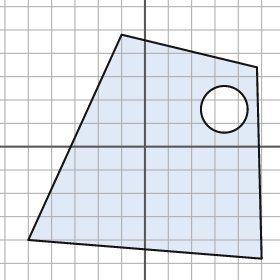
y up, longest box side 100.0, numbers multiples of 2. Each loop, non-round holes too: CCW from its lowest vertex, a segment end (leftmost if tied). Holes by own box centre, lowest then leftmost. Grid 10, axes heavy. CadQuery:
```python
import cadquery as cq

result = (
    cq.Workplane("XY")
    .moveTo(50.0, -48.0)
    .lineTo(48.0, 34.0)
    .lineTo(-10.0, 48.0)
    .lineTo(-50.0, -40.0)
    .close()
    .moveTo(34.0, 16.0)
    .circle(10.0)
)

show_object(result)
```